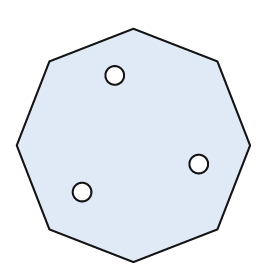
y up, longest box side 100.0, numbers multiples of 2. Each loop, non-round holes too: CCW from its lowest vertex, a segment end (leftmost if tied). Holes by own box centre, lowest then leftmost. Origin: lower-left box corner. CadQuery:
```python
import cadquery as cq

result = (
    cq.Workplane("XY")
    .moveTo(50.0, 0.0)
    .lineTo(86.0, 14.0)
    .lineTo(100.0, 50.0)
    .lineTo(86.0, 86.0)
    .lineTo(50.0, 100.0)
    .lineTo(14.0, 86.0)
    .lineTo(0.0, 50.0)
    .lineTo(14.0, 14.0)
    .close()
    .moveTo(28.0, 30.0)
    .circle(4.0)
    .moveTo(78.0, 42.0)
    .circle(4.0)
    .moveTo(42.0, 80.0)
    .circle(4.0)
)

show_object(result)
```